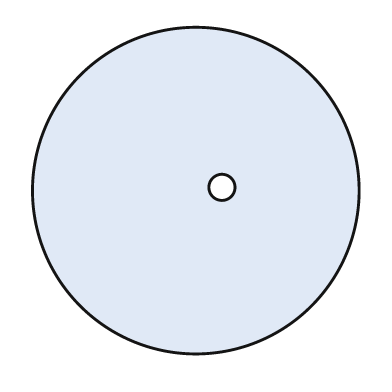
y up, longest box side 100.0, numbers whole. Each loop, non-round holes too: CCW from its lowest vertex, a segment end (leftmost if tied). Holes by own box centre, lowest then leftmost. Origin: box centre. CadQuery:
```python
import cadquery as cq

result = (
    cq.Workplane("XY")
    .moveTo(0.0, 0.0)
    .circle(50.0)
    .moveTo(8.0, 1.0)
    .circle(4.0)
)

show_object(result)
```